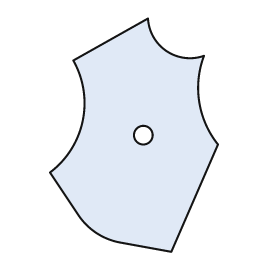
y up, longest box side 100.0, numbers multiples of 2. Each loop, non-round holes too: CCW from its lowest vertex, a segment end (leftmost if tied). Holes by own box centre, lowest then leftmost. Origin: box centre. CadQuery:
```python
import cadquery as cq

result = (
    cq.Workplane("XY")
    .moveTo(16.0, -50.0)
    .lineTo(36.0, -4.0)
    .threePointArc((28.0, 14.0), (30.0, 34.0))
    .threePointArc((14.0, 36.0), (6.0, 50.0))
    .lineTo(-26.0, 32.0)
    .threePointArc((-22.0, 6.0), (-36.0, -16.0))
    .lineTo(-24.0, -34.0)
    .threePointArc((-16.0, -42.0), (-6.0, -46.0))
    .close()
    .moveTo(4.0, 0.0)
    .circle(4.0)
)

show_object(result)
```